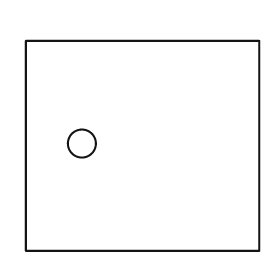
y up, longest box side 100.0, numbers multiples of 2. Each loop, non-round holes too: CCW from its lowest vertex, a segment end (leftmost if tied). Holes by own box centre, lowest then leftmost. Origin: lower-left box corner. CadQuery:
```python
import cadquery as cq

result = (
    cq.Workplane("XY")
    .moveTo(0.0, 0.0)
    .lineTo(100.0, 0.0)
    .lineTo(100.0, 90.0)
    .lineTo(0.0, 90.0)
    .close()
    .moveTo(24.0, 46.0)
    .circle(6.0)
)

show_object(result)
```